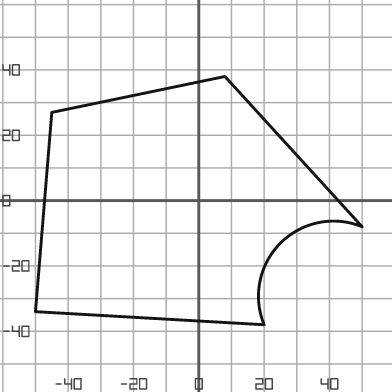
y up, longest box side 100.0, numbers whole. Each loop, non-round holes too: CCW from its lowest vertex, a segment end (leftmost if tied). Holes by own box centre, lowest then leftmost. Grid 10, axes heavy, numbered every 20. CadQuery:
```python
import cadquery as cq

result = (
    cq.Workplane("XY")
    .moveTo(20.0, -38.0)
    .threePointArc((25.0, -13.0), (50.0, -8.0))
    .lineTo(8.0, 38.0)
    .lineTo(-45.0, 27.0)
    .lineTo(-50.0, -34.0)
    .close()
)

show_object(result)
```